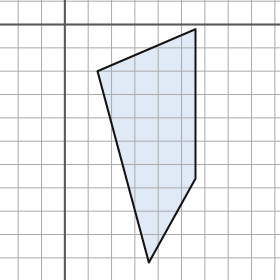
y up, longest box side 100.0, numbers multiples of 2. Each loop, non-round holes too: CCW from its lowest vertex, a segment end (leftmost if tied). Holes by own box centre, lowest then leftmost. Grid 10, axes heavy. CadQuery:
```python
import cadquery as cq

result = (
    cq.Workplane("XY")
    .moveTo(36.0, -102.0)
    .lineTo(56.0, -66.0)
    .lineTo(56.0, -2.0)
    .lineTo(14.0, -20.0)
    .close()
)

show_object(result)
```